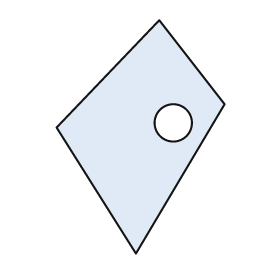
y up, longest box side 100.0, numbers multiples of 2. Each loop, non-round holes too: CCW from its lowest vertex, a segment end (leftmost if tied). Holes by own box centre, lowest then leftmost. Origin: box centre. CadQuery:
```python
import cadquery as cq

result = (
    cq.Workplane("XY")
    .moveTo(-2.0, -50.0)
    .lineTo(36.0, 14.0)
    .lineTo(8.0, 50.0)
    .lineTo(-36.0, 4.0)
    .close()
    .moveTo(14.0, 6.0)
    .circle(8.0)
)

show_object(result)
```